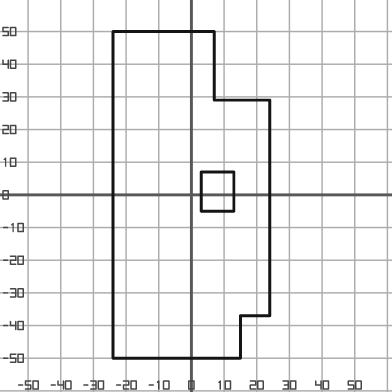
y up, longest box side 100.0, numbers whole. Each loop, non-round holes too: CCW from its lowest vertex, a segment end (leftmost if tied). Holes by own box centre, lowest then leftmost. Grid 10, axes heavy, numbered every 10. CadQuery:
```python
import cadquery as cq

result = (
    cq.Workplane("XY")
    .moveTo(-24.0, -50.0)
    .lineTo(15.0, -50.0)
    .lineTo(15.0, -37.0)
    .lineTo(24.0, -37.0)
    .lineTo(24.0, 29.0)
    .lineTo(7.0, 29.0)
    .lineTo(7.0, 50.0)
    .lineTo(-24.0, 50.0)
    .close()
    .moveTo(3.0, -5.0)
    .lineTo(13.0, -5.0)
    .lineTo(13.0, 7.0)
    .lineTo(3.0, 7.0)
    .close()
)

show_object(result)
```